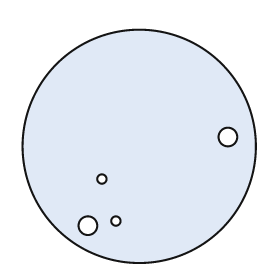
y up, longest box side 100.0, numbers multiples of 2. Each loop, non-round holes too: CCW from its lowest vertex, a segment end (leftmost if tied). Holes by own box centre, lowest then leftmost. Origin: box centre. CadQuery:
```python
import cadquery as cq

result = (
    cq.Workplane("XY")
    .moveTo(0.0, 0.0)
    .circle(50.0)
    .moveTo(-22.0, -34.0)
    .circle(4.0)
    .moveTo(-10.0, -32.0)
    .circle(2.0)
    .moveTo(-16.0, -14.0)
    .circle(2.0)
    .moveTo(38.0, 4.0)
    .circle(4.0)
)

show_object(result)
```